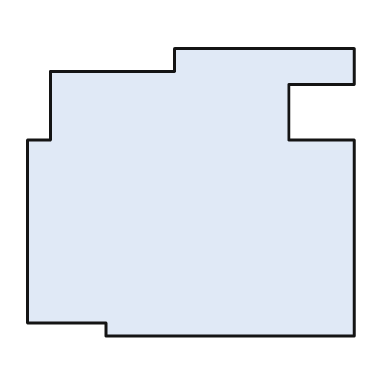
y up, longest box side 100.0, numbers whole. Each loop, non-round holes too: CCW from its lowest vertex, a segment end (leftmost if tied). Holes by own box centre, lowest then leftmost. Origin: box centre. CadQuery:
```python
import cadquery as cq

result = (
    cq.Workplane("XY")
    .moveTo(-26.0, -44.0)
    .lineTo(50.0, -44.0)
    .lineTo(50.0, 16.0)
    .lineTo(30.0, 16.0)
    .lineTo(30.0, 33.0)
    .lineTo(50.0, 33.0)
    .lineTo(50.0, 44.0)
    .lineTo(-5.0, 44.0)
    .lineTo(-5.0, 37.0)
    .lineTo(-43.0, 37.0)
    .lineTo(-43.0, 16.0)
    .lineTo(-50.0, 16.0)
    .lineTo(-50.0, -40.0)
    .lineTo(-26.0, -40.0)
    .close()
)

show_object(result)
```